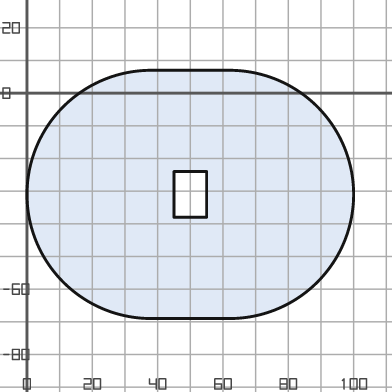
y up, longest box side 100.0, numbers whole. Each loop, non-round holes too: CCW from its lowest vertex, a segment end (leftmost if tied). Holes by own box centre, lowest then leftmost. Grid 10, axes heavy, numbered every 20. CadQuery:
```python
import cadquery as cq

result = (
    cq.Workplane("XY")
    .moveTo(38.0, -69.0)
    .lineTo(62.0, -69.0)
    .threePointArc((100.0, -31.0), (62.0, 7.0))
    .lineTo(38.0, 7.0)
    .threePointArc((0.0, -31.0), (38.0, -69.0))
    .close()
    .moveTo(45.0, -38.0)
    .lineTo(55.0, -38.0)
    .lineTo(55.0, -24.0)
    .lineTo(45.0, -24.0)
    .close()
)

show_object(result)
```